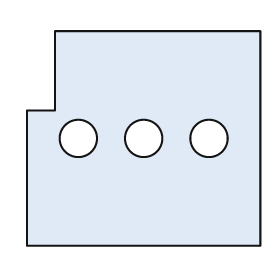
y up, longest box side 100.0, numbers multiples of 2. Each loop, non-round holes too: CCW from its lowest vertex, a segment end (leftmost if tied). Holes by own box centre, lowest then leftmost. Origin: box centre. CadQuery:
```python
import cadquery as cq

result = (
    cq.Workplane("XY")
    .moveTo(-50.0, -46.0)
    .lineTo(50.0, -46.0)
    .lineTo(50.0, 46.0)
    .lineTo(-38.0, 46.0)
    .lineTo(-38.0, 12.0)
    .lineTo(-50.0, 12.0)
    .close()
    .moveTo(-28.0, 0.0)
    .circle(8.0)
    .moveTo(0.0, 0.0)
    .circle(8.0)
    .moveTo(28.0, 0.0)
    .circle(8.0)
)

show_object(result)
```